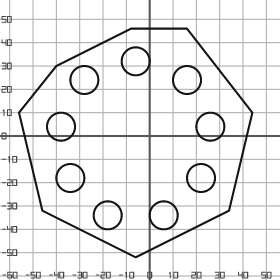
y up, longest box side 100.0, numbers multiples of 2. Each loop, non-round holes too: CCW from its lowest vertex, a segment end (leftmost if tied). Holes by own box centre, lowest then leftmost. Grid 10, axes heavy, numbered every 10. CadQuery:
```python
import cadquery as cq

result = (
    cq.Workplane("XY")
    .moveTo(-6.0, -52.0)
    .lineTo(34.0, -32.0)
    .lineTo(44.0, 10.0)
    .lineTo(16.0, 46.0)
    .lineTo(-8.0, 46.0)
    .lineTo(-40.0, 30.0)
    .lineTo(-56.0, 10.0)
    .lineTo(-46.0, -32.0)
    .close()
    .moveTo(-18.0, -34.0)
    .circle(6.0)
    .moveTo(6.0, -34.0)
    .circle(6.0)
    .moveTo(-34.0, -18.0)
    .circle(6.0)
    .moveTo(22.0, -18.0)
    .circle(6.0)
    .moveTo(-38.0, 4.0)
    .circle(6.0)
    .moveTo(26.0, 4.0)
    .circle(6.0)
    .moveTo(-28.0, 24.0)
    .circle(6.0)
    .moveTo(16.0, 24.0)
    .circle(6.0)
    .moveTo(-6.0, 32.0)
    .circle(6.0)
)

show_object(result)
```